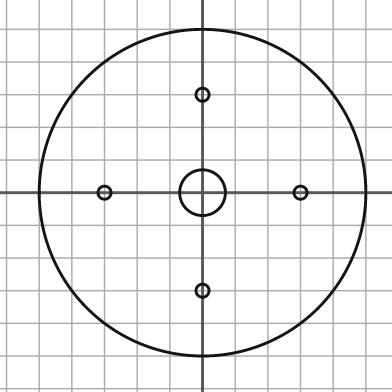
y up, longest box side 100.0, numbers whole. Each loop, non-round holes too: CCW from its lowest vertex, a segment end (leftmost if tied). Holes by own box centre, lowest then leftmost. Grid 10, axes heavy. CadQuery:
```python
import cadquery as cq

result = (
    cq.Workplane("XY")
    .moveTo(0.0, 0.0)
    .circle(50.0)
    .moveTo(0.0, -30.0)
    .circle(2.0)
    .moveTo(-30.0, 0.0)
    .circle(2.0)
    .moveTo(0.0, 0.0)
    .circle(7.0)
    .moveTo(30.0, 0.0)
    .circle(2.0)
    .moveTo(0.0, 30.0)
    .circle(2.0)
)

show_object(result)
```